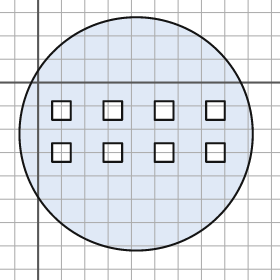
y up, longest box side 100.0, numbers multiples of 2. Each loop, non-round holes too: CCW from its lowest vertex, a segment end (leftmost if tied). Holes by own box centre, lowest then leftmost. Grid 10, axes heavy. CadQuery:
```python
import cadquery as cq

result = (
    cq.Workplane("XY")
    .moveTo(42.0, -22.0)
    .circle(50.0)
    .moveTo(6.0, -34.0)
    .lineTo(14.0, -34.0)
    .lineTo(14.0, -26.0)
    .lineTo(6.0, -26.0)
    .close()
    .moveTo(28.0, -34.0)
    .lineTo(36.0, -34.0)
    .lineTo(36.0, -26.0)
    .lineTo(28.0, -26.0)
    .close()
    .moveTo(50.0, -34.0)
    .lineTo(58.0, -34.0)
    .lineTo(58.0, -26.0)
    .lineTo(50.0, -26.0)
    .close()
    .moveTo(72.0, -34.0)
    .lineTo(80.0, -34.0)
    .lineTo(80.0, -26.0)
    .lineTo(72.0, -26.0)
    .close()
    .moveTo(6.0, -16.0)
    .lineTo(14.0, -16.0)
    .lineTo(14.0, -8.0)
    .lineTo(6.0, -8.0)
    .close()
    .moveTo(28.0, -16.0)
    .lineTo(36.0, -16.0)
    .lineTo(36.0, -8.0)
    .lineTo(28.0, -8.0)
    .close()
    .moveTo(50.0, -16.0)
    .lineTo(58.0, -16.0)
    .lineTo(58.0, -8.0)
    .lineTo(50.0, -8.0)
    .close()
    .moveTo(72.0, -16.0)
    .lineTo(80.0, -16.0)
    .lineTo(80.0, -8.0)
    .lineTo(72.0, -8.0)
    .close()
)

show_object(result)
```